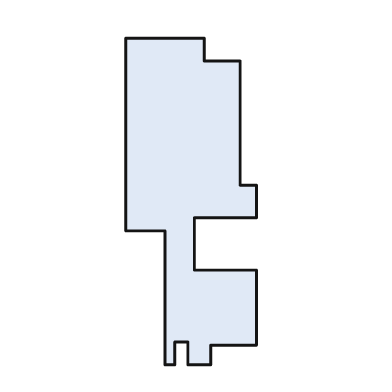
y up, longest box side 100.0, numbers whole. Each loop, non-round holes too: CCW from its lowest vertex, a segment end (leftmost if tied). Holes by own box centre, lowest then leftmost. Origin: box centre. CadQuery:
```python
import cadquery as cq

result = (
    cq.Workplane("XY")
    .moveTo(-8.0, -50.0)
    .lineTo(-5.0, -50.0)
    .lineTo(-5.0, -43.0)
    .lineTo(-1.0, -43.0)
    .lineTo(-1.0, -50.0)
    .lineTo(6.0, -50.0)
    .lineTo(6.0, -44.0)
    .lineTo(20.0, -44.0)
    .lineTo(20.0, -21.0)
    .lineTo(1.0, -21.0)
    .lineTo(1.0, -5.0)
    .lineTo(20.0, -5.0)
    .lineTo(20.0, 5.0)
    .lineTo(15.0, 5.0)
    .lineTo(15.0, 43.0)
    .lineTo(4.0, 43.0)
    .lineTo(4.0, 50.0)
    .lineTo(-20.0, 50.0)
    .lineTo(-20.0, -9.0)
    .lineTo(-8.0, -9.0)
    .close()
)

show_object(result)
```